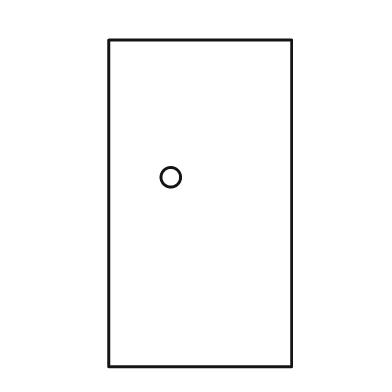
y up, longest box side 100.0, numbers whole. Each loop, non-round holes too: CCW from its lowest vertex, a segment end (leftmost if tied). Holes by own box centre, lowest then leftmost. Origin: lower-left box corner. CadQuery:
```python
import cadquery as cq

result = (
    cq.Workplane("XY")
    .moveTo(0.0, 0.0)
    .lineTo(56.0, 0.0)
    .lineTo(56.0, 100.0)
    .lineTo(0.0, 100.0)
    .close()
    .moveTo(19.0, 58.0)
    .circle(3.0)
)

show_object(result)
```